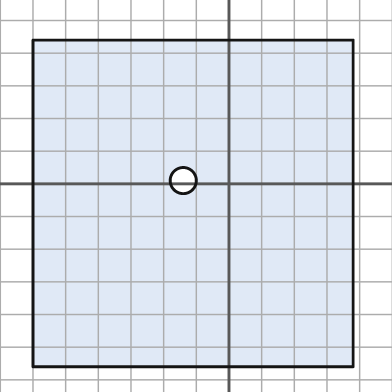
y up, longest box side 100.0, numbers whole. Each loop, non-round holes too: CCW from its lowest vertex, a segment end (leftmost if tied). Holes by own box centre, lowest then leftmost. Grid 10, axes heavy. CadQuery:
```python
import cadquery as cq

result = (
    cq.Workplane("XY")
    .moveTo(-60.0, -56.0)
    .lineTo(38.0, -56.0)
    .lineTo(38.0, 44.0)
    .lineTo(-60.0, 44.0)
    .close()
    .moveTo(-14.0, 1.0)
    .circle(4.0)
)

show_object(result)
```